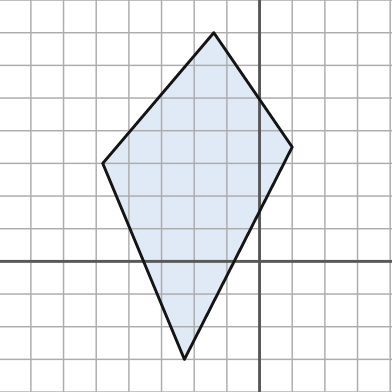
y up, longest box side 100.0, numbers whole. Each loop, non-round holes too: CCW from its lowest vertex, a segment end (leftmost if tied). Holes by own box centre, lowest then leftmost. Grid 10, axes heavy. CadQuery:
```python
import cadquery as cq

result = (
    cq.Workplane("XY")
    .moveTo(-23.0, -30.0)
    .lineTo(10.0, 35.0)
    .lineTo(-14.0, 70.0)
    .lineTo(-48.0, 30.0)
    .close()
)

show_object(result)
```